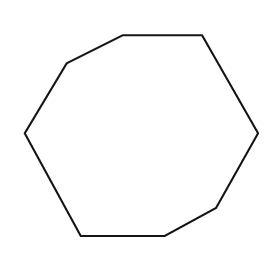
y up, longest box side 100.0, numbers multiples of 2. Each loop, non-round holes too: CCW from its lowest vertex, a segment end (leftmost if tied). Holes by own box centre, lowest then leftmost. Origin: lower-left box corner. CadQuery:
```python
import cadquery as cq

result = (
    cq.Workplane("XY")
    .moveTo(24.0, 0.0)
    .lineTo(60.0, 0.0)
    .lineTo(82.0, 12.0)
    .lineTo(100.0, 44.0)
    .lineTo(76.0, 86.0)
    .lineTo(42.0, 86.0)
    .lineTo(18.0, 74.0)
    .lineTo(0.0, 44.0)
    .close()
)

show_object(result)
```